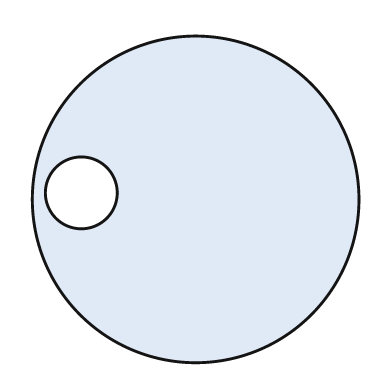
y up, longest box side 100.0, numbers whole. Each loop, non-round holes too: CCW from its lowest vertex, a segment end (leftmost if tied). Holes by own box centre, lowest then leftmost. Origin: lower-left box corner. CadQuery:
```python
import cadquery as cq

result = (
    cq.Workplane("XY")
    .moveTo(50.0, 50.0)
    .circle(50.0)
    .moveTo(15.0, 52.0)
    .circle(11.0)
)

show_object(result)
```